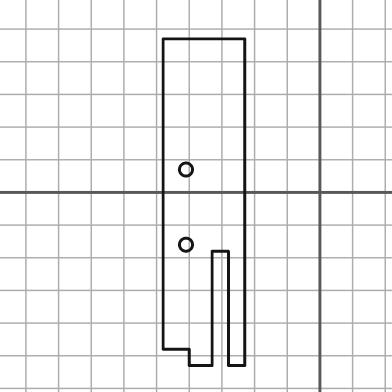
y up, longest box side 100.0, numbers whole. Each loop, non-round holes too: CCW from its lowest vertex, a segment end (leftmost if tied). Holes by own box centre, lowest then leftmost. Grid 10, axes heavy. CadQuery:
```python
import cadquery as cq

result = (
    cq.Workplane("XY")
    .moveTo(-40.0, -53.0)
    .lineTo(-33.0, -53.0)
    .lineTo(-33.0, -18.0)
    .lineTo(-28.0, -18.0)
    .lineTo(-28.0, -53.0)
    .lineTo(-23.0, -53.0)
    .lineTo(-23.0, 47.0)
    .lineTo(-48.0, 47.0)
    .lineTo(-48.0, -48.0)
    .lineTo(-40.0, -48.0)
    .close()
    .moveTo(-41.0, -16.0)
    .circle(2.0)
    .moveTo(-41.0, 7.0)
    .circle(2.0)
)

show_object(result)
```